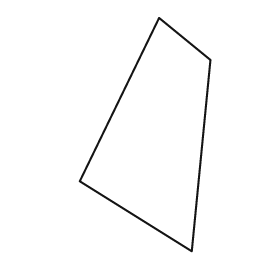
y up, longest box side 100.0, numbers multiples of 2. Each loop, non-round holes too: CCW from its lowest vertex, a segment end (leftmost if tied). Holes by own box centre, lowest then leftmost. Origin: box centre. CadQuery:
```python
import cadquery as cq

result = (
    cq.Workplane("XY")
    .moveTo(20.0, -50.0)
    .lineTo(28.0, 32.0)
    .lineTo(6.0, 50.0)
    .lineTo(-28.0, -20.0)
    .close()
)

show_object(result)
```